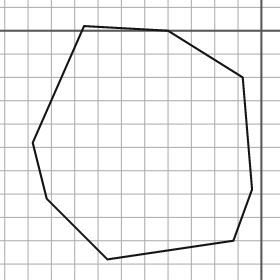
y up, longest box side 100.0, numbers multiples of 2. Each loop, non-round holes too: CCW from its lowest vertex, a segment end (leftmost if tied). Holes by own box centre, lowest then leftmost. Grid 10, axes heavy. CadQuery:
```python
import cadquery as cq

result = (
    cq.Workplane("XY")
    .moveTo(-66.0, -98.0)
    .lineTo(-12.0, -90.0)
    .lineTo(-4.0, -68.0)
    .lineTo(-8.0, -20.0)
    .lineTo(-40.0, 0.0)
    .lineTo(-76.0, 2.0)
    .lineTo(-98.0, -48.0)
    .lineTo(-92.0, -72.0)
    .close()
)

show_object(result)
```